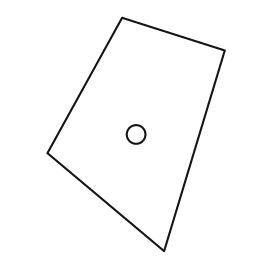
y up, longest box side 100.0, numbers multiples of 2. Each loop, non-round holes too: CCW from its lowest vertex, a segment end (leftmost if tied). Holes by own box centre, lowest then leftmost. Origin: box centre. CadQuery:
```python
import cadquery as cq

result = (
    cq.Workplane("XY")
    .moveTo(12.0, -50.0)
    .lineTo(38.0, 36.0)
    .lineTo(-6.0, 50.0)
    .lineTo(-38.0, -8.0)
    .close()
    .moveTo(0.0, 0.0)
    .circle(4.0)
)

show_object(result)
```